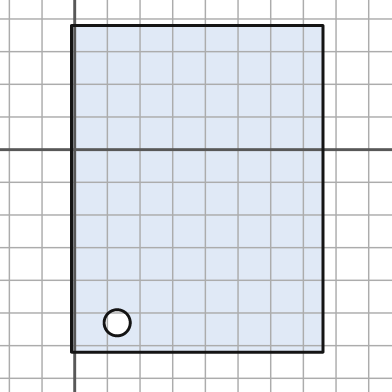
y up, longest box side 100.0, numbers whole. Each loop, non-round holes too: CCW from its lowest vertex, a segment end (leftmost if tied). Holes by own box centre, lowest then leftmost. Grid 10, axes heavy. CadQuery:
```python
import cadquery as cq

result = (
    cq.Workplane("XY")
    .moveTo(-1.0, -62.0)
    .lineTo(76.0, -62.0)
    .lineTo(76.0, 38.0)
    .lineTo(-1.0, 38.0)
    .close()
    .moveTo(13.0, -53.0)
    .circle(4.0)
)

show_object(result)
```